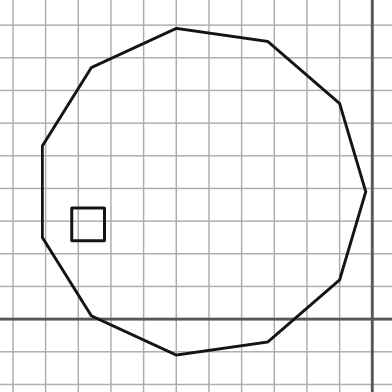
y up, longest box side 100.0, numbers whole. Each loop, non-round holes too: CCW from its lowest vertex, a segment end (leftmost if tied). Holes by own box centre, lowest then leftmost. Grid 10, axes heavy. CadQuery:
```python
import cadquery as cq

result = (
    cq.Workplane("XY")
    .moveTo(-60.0, -11.0)
    .lineTo(-32.0, -7.0)
    .lineTo(-10.0, 12.0)
    .lineTo(-2.0, 39.0)
    .lineTo(-10.0, 66.0)
    .lineTo(-32.0, 85.0)
    .lineTo(-60.0, 89.0)
    .lineTo(-86.0, 77.0)
    .lineTo(-101.0, 53.0)
    .lineTo(-101.0, 25.0)
    .lineTo(-86.0, 1.0)
    .close()
    .moveTo(-92.0, 24.0)
    .lineTo(-82.0, 24.0)
    .lineTo(-82.0, 34.0)
    .lineTo(-92.0, 34.0)
    .close()
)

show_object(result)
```